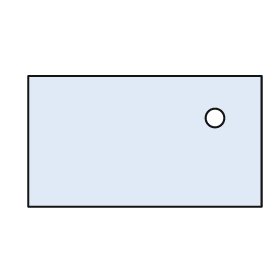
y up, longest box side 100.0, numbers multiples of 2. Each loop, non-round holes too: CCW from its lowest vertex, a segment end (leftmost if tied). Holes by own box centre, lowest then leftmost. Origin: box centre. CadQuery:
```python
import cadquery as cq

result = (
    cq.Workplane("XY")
    .moveTo(-50.0, -28.0)
    .lineTo(50.0, -28.0)
    .lineTo(50.0, 28.0)
    .lineTo(-50.0, 28.0)
    .close()
    .moveTo(30.0, 10.0)
    .circle(4.0)
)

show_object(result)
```